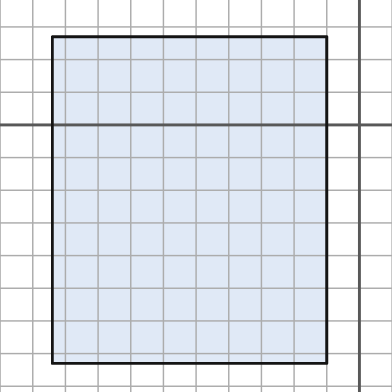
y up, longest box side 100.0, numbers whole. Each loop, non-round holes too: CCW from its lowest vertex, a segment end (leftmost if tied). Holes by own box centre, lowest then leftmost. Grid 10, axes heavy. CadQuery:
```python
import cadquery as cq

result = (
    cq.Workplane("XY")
    .moveTo(-94.0, -73.0)
    .lineTo(-10.0, -73.0)
    .lineTo(-10.0, 27.0)
    .lineTo(-94.0, 27.0)
    .close()
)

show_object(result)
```